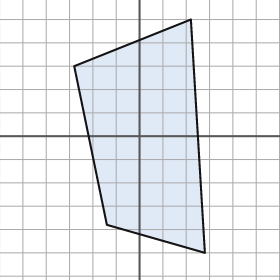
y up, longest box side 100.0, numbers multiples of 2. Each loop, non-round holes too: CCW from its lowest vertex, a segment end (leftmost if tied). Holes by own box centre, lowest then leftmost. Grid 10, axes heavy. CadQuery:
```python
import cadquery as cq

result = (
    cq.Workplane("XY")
    .moveTo(28.0, -50.0)
    .lineTo(22.0, 50.0)
    .lineTo(-28.0, 30.0)
    .lineTo(-14.0, -38.0)
    .close()
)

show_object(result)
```